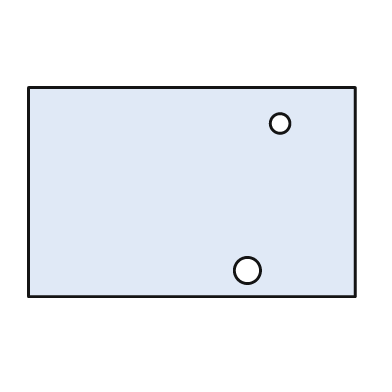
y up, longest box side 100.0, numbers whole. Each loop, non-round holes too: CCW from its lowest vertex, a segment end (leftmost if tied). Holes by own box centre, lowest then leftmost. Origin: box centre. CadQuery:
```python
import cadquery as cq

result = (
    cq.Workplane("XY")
    .moveTo(-50.0, -32.0)
    .lineTo(50.0, -32.0)
    .lineTo(50.0, 32.0)
    .lineTo(-50.0, 32.0)
    .close()
    .moveTo(17.0, -24.0)
    .circle(4.0)
    .moveTo(27.0, 21.0)
    .circle(3.0)
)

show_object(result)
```